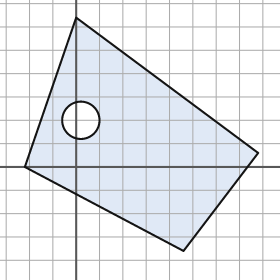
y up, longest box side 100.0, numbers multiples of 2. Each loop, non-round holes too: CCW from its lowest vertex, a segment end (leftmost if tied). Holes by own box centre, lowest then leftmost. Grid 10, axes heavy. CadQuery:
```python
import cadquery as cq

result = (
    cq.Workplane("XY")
    .moveTo(46.0, -36.0)
    .lineTo(78.0, 6.0)
    .lineTo(0.0, 64.0)
    .lineTo(-22.0, 0.0)
    .close()
    .moveTo(2.0, 20.0)
    .circle(8.0)
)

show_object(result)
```